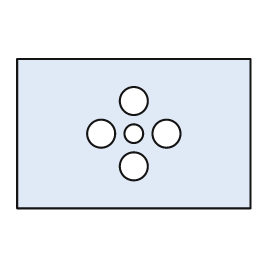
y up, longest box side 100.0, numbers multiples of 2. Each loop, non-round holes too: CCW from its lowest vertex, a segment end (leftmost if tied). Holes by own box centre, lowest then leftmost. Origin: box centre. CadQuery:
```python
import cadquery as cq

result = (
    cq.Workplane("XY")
    .moveTo(-50.0, -32.0)
    .lineTo(50.0, -32.0)
    .lineTo(50.0, 32.0)
    .lineTo(-50.0, 32.0)
    .close()
    .moveTo(0.0, -14.0)
    .circle(6.0)
    .moveTo(-14.0, 0.0)
    .circle(6.0)
    .moveTo(0.0, 0.0)
    .circle(4.0)
    .moveTo(14.0, 0.0)
    .circle(6.0)
    .moveTo(0.0, 14.0)
    .circle(6.0)
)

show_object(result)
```